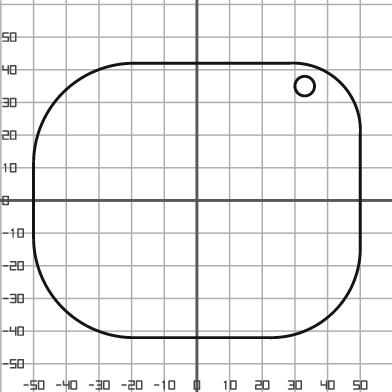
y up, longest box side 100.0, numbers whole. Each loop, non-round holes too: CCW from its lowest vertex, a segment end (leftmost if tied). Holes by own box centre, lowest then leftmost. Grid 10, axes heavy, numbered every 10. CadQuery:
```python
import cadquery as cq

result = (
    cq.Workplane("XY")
    .moveTo(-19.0, -42.0)
    .lineTo(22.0, -42.0)
    .threePointArc((42.0, -34.0), (50.0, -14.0))
    .lineTo(50.0, 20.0)
    .threePointArc((44.0, 36.0), (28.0, 42.0))
    .lineTo(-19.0, 42.0)
    .threePointArc((-41.0, 33.0), (-50.0, 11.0))
    .lineTo(-50.0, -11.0)
    .threePointArc((-41.0, -33.0), (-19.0, -42.0))
    .close()
    .moveTo(33.0, 35.0)
    .circle(3.0)
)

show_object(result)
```